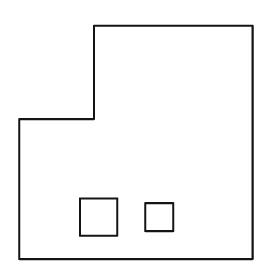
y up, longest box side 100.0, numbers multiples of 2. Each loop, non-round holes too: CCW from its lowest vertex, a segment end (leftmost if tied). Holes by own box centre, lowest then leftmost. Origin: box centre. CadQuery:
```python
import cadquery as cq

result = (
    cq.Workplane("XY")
    .moveTo(-50.0, -50.0)
    .lineTo(50.0, -50.0)
    .lineTo(50.0, 50.0)
    .lineTo(-18.0, 50.0)
    .lineTo(-18.0, 10.0)
    .lineTo(-50.0, 10.0)
    .close()
    .moveTo(-24.0, -40.0)
    .lineTo(-8.0, -40.0)
    .lineTo(-8.0, -24.0)
    .lineTo(-24.0, -24.0)
    .close()
    .moveTo(4.0, -38.0)
    .lineTo(16.0, -38.0)
    .lineTo(16.0, -26.0)
    .lineTo(4.0, -26.0)
    .close()
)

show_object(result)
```